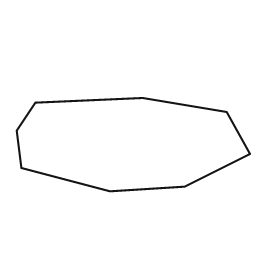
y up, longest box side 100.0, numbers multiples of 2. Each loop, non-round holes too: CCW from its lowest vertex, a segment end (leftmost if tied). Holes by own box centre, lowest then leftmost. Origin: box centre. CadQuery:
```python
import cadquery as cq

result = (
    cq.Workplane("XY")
    .moveTo(-10.0, -20.0)
    .lineTo(22.0, -18.0)
    .lineTo(50.0, -4.0)
    .lineTo(40.0, 14.0)
    .lineTo(4.0, 20.0)
    .lineTo(-42.0, 18.0)
    .lineTo(-50.0, 6.0)
    .lineTo(-48.0, -10.0)
    .close()
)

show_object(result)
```